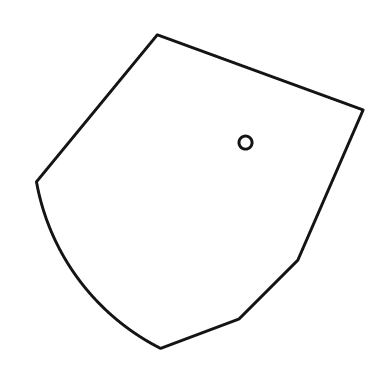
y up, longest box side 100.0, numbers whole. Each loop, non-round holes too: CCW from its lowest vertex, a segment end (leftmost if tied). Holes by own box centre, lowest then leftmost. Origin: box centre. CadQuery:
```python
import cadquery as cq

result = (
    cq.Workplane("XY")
    .moveTo(-12.0, -48.0)
    .lineTo(12.0, -39.0)
    .lineTo(30.0, -21.0)
    .lineTo(50.0, 25.0)
    .lineTo(-13.0, 48.0)
    .lineTo(-50.0, 3.0)
    .threePointArc((-37.0, -27.0), (-12.0, -48.0))
    .close()
    .moveTo(14.0, 15.0)
    .circle(2.0)
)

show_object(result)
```